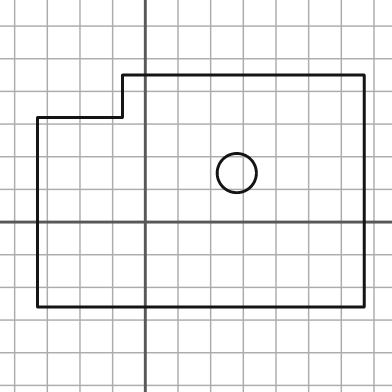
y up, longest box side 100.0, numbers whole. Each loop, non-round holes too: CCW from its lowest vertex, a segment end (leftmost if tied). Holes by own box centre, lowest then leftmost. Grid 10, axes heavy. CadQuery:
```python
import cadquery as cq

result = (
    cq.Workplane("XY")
    .moveTo(-33.0, -26.0)
    .lineTo(67.0, -26.0)
    .lineTo(67.0, 45.0)
    .lineTo(-7.0, 45.0)
    .lineTo(-7.0, 32.0)
    .lineTo(-33.0, 32.0)
    .close()
    .moveTo(28.0, 15.0)
    .circle(6.0)
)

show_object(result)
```